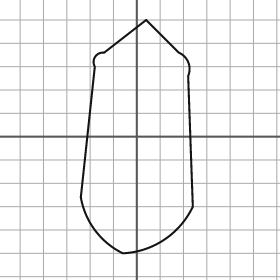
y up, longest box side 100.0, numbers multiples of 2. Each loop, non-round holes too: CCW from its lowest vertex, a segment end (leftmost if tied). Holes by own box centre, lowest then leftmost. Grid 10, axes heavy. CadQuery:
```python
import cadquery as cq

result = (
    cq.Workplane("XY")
    .moveTo(-6.0, -50.0)
    .threePointArc((12.0, -44.0), (24.0, -30.0))
    .lineTo(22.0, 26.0)
    .threePointArc((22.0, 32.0), (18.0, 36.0))
    .lineTo(4.0, 50.0)
    .lineTo(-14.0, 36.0)
    .threePointArc((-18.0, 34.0), (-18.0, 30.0))
    .lineTo(-24.0, -26.0)
    .threePointArc((-18.0, -40.0), (-6.0, -50.0))
    .close()
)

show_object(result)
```